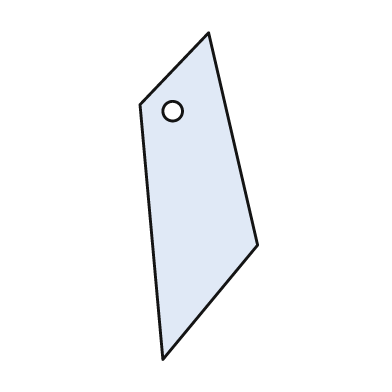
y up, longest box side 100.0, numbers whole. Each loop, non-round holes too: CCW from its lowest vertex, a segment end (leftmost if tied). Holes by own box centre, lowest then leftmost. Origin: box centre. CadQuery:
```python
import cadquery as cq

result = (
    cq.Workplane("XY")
    .moveTo(-11.0, -50.0)
    .lineTo(18.0, -15.0)
    .lineTo(3.0, 50.0)
    .lineTo(-18.0, 28.0)
    .close()
    .moveTo(-8.0, 26.0)
    .circle(3.0)
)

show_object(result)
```